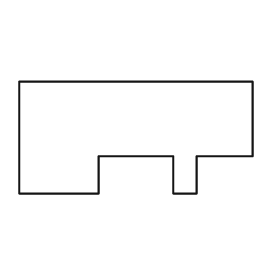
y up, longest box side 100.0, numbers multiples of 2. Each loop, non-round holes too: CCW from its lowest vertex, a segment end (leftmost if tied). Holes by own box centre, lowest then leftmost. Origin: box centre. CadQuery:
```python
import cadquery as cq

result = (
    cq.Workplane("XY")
    .moveTo(-50.0, -24.0)
    .lineTo(-16.0, -24.0)
    .lineTo(-16.0, -8.0)
    .lineTo(16.0, -8.0)
    .lineTo(16.0, -24.0)
    .lineTo(26.0, -24.0)
    .lineTo(26.0, -8.0)
    .lineTo(50.0, -8.0)
    .lineTo(50.0, 24.0)
    .lineTo(-50.0, 24.0)
    .close()
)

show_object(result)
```